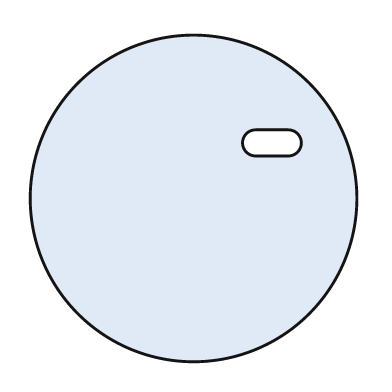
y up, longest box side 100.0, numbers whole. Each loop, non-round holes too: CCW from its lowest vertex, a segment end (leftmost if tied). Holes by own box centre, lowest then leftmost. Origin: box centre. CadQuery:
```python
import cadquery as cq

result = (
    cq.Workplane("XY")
    .moveTo(0.0, 0.0)
    .circle(50.0)
    .moveTo(19.0, 13.0)
    .lineTo(29.0, 13.0)
    .threePointArc((33.0, 17.0), (29.0, 21.0))
    .lineTo(19.0, 21.0)
    .threePointArc((15.0, 17.0), (19.0, 13.0))
    .close()
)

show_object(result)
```